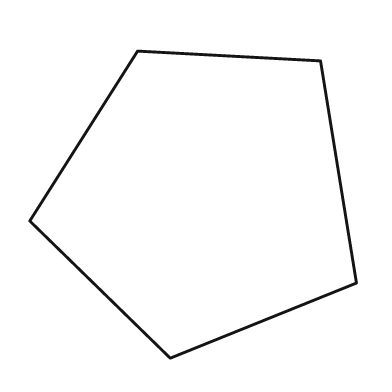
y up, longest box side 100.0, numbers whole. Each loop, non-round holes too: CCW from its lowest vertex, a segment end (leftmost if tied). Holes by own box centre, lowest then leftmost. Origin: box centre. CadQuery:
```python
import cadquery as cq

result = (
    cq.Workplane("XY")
    .moveTo(-7.0, -47.0)
    .lineTo(50.0, -24.0)
    .lineTo(39.0, 44.0)
    .lineTo(-17.0, 47.0)
    .lineTo(-50.0, -5.0)
    .close()
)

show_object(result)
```